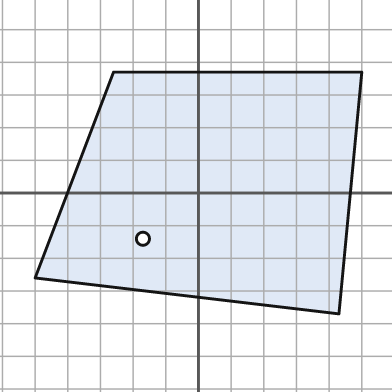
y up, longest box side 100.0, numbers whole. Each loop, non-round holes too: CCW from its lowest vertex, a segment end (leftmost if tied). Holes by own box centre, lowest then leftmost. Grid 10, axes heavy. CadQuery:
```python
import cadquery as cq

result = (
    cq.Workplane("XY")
    .moveTo(43.0, -37.0)
    .lineTo(50.0, 37.0)
    .lineTo(-26.0, 37.0)
    .lineTo(-50.0, -26.0)
    .close()
    .moveTo(-17.0, -14.0)
    .circle(2.0)
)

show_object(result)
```